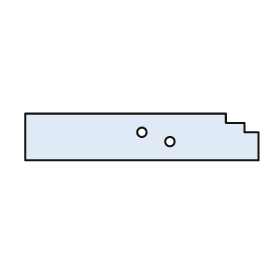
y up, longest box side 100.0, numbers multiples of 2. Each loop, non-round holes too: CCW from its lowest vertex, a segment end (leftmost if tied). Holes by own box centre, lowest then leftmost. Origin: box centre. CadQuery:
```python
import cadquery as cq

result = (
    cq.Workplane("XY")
    .moveTo(-50.0, -10.0)
    .lineTo(50.0, -10.0)
    .lineTo(50.0, 2.0)
    .lineTo(44.0, 2.0)
    .lineTo(44.0, 6.0)
    .lineTo(36.0, 6.0)
    .lineTo(36.0, 10.0)
    .lineTo(-50.0, 10.0)
    .close()
    .moveTo(12.0, -2.0)
    .circle(2.0)
    .moveTo(0.0, 2.0)
    .circle(2.0)
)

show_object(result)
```